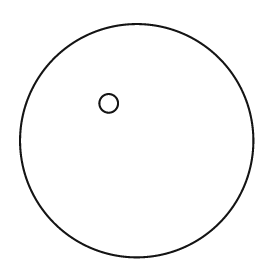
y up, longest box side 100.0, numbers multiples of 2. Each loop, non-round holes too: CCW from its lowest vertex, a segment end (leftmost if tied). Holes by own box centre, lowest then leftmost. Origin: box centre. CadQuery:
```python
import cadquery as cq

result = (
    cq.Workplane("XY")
    .moveTo(0.0, 0.0)
    .circle(50.0)
    .moveTo(-12.0, 16.0)
    .circle(4.0)
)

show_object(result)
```